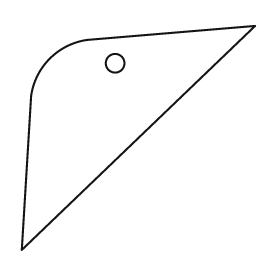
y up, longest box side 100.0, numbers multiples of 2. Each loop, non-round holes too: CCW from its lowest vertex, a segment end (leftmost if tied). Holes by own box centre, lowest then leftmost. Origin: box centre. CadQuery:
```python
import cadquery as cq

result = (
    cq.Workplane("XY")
    .moveTo(-50.0, -48.0)
    .lineTo(50.0, 48.0)
    .lineTo(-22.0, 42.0)
    .threePointArc((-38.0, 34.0), (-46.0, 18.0))
    .close()
    .moveTo(-10.0, 32.0)
    .circle(4.0)
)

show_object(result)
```